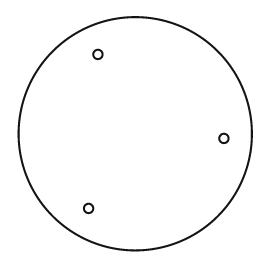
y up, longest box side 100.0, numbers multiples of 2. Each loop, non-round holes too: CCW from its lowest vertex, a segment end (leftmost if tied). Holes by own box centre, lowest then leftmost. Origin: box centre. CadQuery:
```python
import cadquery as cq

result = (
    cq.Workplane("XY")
    .moveTo(0.0, 0.0)
    .circle(50.0)
    .moveTo(-20.0, -32.0)
    .circle(2.0)
    .moveTo(38.0, -2.0)
    .circle(2.0)
    .moveTo(-16.0, 34.0)
    .circle(2.0)
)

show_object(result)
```